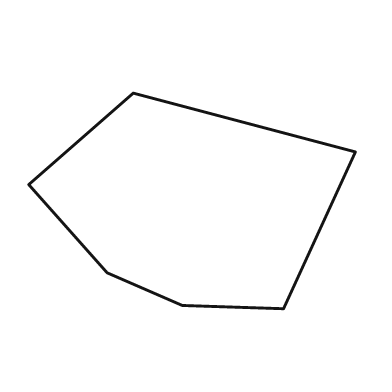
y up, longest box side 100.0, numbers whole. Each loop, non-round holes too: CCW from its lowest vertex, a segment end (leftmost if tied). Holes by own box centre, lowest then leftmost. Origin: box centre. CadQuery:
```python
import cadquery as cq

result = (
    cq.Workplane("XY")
    .moveTo(28.0, -33.0)
    .lineTo(50.0, 15.0)
    .lineTo(-18.0, 33.0)
    .lineTo(-50.0, 5.0)
    .lineTo(-26.0, -22.0)
    .lineTo(-3.0, -32.0)
    .close()
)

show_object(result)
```